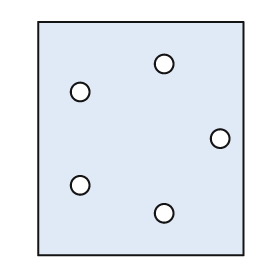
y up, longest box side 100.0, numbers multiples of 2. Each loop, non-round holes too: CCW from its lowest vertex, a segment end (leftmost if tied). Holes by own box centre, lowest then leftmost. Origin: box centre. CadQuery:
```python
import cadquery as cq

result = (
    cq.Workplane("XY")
    .moveTo(-44.0, -50.0)
    .lineTo(44.0, -50.0)
    .lineTo(44.0, 50.0)
    .lineTo(-44.0, 50.0)
    .close()
    .moveTo(10.0, -32.0)
    .circle(4.0)
    .moveTo(-26.0, -20.0)
    .circle(4.0)
    .moveTo(34.0, 0.0)
    .circle(4.0)
    .moveTo(-26.0, 20.0)
    .circle(4.0)
    .moveTo(10.0, 32.0)
    .circle(4.0)
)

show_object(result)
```